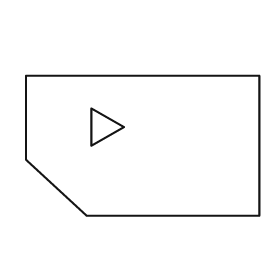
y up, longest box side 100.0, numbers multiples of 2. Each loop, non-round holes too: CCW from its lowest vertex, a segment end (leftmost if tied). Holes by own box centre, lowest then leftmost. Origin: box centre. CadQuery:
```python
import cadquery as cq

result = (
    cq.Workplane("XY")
    .moveTo(-24.0, -30.0)
    .lineTo(50.0, -30.0)
    .lineTo(50.0, 30.0)
    .lineTo(-50.0, 30.0)
    .lineTo(-50.0, -6.0)
    .close()
    .moveTo(-22.0, 0.0)
    .lineTo(-8.0, 8.0)
    .lineTo(-22.0, 16.0)
    .close()
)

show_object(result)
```